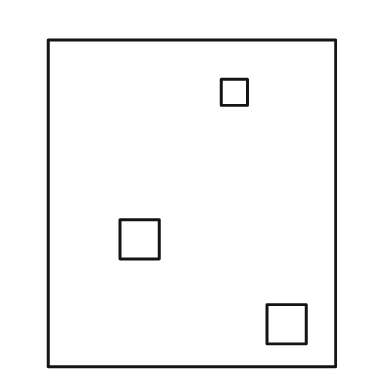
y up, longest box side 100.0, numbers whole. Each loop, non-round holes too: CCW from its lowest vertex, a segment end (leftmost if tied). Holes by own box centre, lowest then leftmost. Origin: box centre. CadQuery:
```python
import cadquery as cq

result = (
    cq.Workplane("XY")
    .moveTo(-44.0, -50.0)
    .lineTo(44.0, -50.0)
    .lineTo(44.0, 50.0)
    .lineTo(-44.0, 50.0)
    .close()
    .moveTo(23.0, -43.0)
    .lineTo(35.0, -43.0)
    .lineTo(35.0, -31.0)
    .lineTo(23.0, -31.0)
    .close()
    .moveTo(-22.0, -17.0)
    .lineTo(-10.0, -17.0)
    .lineTo(-10.0, -5.0)
    .lineTo(-22.0, -5.0)
    .close()
    .moveTo(9.0, 30.0)
    .lineTo(17.0, 30.0)
    .lineTo(17.0, 38.0)
    .lineTo(9.0, 38.0)
    .close()
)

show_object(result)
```